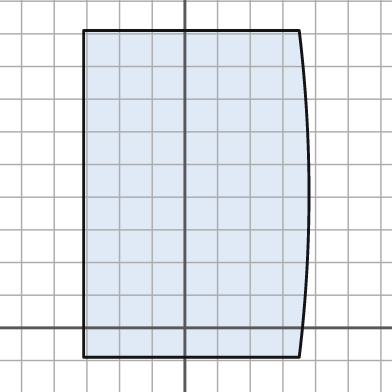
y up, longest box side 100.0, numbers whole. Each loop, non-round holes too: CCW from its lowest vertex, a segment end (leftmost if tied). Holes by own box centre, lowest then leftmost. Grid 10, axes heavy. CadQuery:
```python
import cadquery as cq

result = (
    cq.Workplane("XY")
    .moveTo(-31.0, -9.0)
    .lineTo(35.0, -9.0)
    .threePointArc((38.0, 41.0), (35.0, 91.0))
    .lineTo(-31.0, 91.0)
    .close()
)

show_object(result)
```